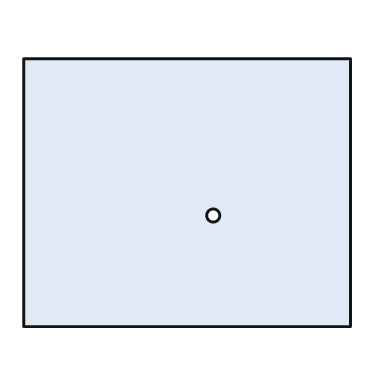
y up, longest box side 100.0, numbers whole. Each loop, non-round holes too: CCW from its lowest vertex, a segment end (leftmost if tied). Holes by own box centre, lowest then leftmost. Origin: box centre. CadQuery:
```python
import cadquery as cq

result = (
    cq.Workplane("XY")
    .moveTo(-50.0, -41.0)
    .lineTo(50.0, -41.0)
    .lineTo(50.0, 41.0)
    .lineTo(-50.0, 41.0)
    .close()
    .moveTo(8.0, -7.0)
    .circle(2.0)
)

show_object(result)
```